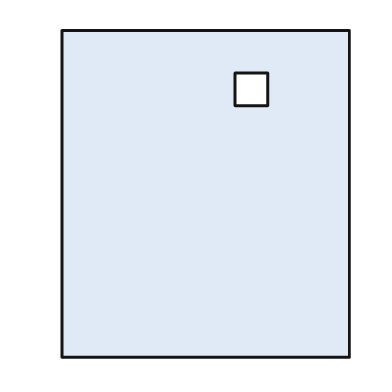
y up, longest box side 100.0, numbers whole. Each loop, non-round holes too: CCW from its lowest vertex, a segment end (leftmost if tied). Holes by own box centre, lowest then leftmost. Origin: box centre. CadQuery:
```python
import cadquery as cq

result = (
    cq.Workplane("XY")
    .moveTo(-44.0, -50.0)
    .lineTo(44.0, -50.0)
    .lineTo(44.0, 50.0)
    .lineTo(-44.0, 50.0)
    .close()
    .moveTo(9.0, 27.0)
    .lineTo(19.0, 27.0)
    .lineTo(19.0, 37.0)
    .lineTo(9.0, 37.0)
    .close()
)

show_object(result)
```